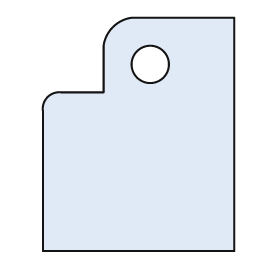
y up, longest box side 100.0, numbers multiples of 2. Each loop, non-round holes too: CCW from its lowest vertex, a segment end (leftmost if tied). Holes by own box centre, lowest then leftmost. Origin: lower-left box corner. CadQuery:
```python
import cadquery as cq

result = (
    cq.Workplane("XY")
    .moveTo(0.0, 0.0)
    .lineTo(82.0, 0.0)
    .lineTo(82.0, 100.0)
    .lineTo(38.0, 100.0)
    .threePointArc((30.0, 96.0), (26.0, 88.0))
    .lineTo(26.0, 68.0)
    .lineTo(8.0, 68.0)
    .threePointArc((2.0, 66.0), (0.0, 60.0))
    .close()
    .moveTo(46.0, 80.0)
    .circle(8.0)
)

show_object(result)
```